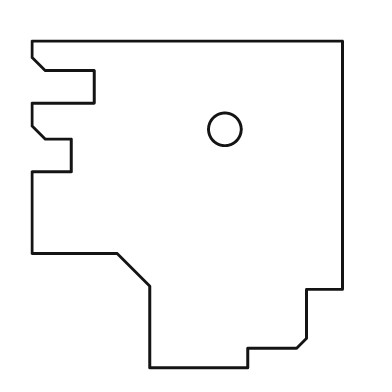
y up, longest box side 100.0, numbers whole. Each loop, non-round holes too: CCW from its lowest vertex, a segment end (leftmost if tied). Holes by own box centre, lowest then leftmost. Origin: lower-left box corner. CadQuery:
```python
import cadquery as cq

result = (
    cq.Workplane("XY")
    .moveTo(36.0, 0.0)
    .lineTo(66.0, 0.0)
    .lineTo(66.0, 6.0)
    .lineTo(81.0, 6.0)
    .lineTo(84.0, 9.0)
    .lineTo(84.0, 24.0)
    .lineTo(95.0, 24.0)
    .lineTo(95.0, 100.0)
    .lineTo(0.0, 100.0)
    .lineTo(0.0, 95.0)
    .lineTo(4.0, 91.0)
    .lineTo(19.0, 91.0)
    .lineTo(19.0, 81.0)
    .lineTo(0.0, 81.0)
    .lineTo(0.0, 74.0)
    .lineTo(4.0, 70.0)
    .lineTo(12.0, 70.0)
    .lineTo(12.0, 60.0)
    .lineTo(0.0, 60.0)
    .lineTo(0.0, 35.0)
    .lineTo(26.0, 35.0)
    .lineTo(36.0, 25.0)
    .close()
    .moveTo(59.0, 73.0)
    .circle(5.0)
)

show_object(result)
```